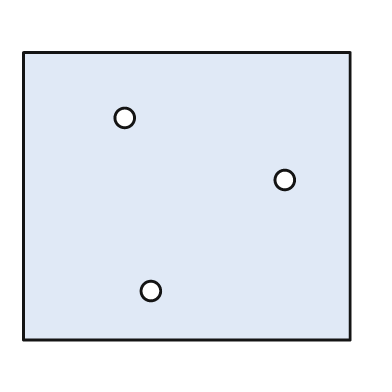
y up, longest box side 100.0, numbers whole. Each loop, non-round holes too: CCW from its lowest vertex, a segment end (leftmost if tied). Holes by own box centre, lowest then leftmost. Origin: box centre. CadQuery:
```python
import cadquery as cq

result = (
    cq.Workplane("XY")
    .moveTo(-50.0, -44.0)
    .lineTo(50.0, -44.0)
    .lineTo(50.0, 44.0)
    .lineTo(-50.0, 44.0)
    .close()
    .moveTo(-11.0, -29.0)
    .circle(3.0)
    .moveTo(30.0, 5.0)
    .circle(3.0)
    .moveTo(-19.0, 24.0)
    .circle(3.0)
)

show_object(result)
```